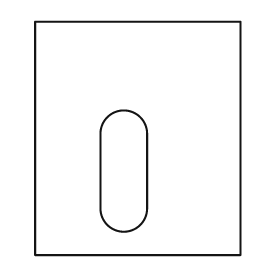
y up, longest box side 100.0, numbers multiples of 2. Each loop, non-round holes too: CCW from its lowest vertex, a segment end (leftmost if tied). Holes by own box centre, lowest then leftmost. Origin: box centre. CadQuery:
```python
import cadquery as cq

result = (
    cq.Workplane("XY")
    .moveTo(-44.0, -50.0)
    .lineTo(44.0, -50.0)
    .lineTo(44.0, 50.0)
    .lineTo(-44.0, 50.0)
    .close()
    .moveTo(-16.0, -30.0)
    .threePointArc((-6.0, -40.0), (4.0, -30.0))
    .lineTo(4.0, 2.0)
    .threePointArc((-6.0, 12.0), (-16.0, 2.0))
    .close()
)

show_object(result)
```